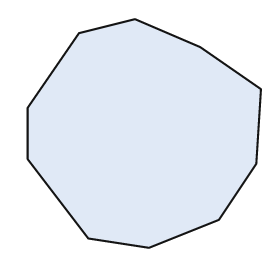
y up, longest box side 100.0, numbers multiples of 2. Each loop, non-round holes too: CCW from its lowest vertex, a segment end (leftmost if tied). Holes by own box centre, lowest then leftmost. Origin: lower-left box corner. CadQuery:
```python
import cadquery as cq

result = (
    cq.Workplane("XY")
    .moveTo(52.0, 0.0)
    .lineTo(82.0, 12.0)
    .lineTo(98.0, 36.0)
    .lineTo(100.0, 68.0)
    .lineTo(74.0, 86.0)
    .lineTo(46.0, 98.0)
    .lineTo(22.0, 92.0)
    .lineTo(0.0, 60.0)
    .lineTo(0.0, 38.0)
    .lineTo(26.0, 4.0)
    .close()
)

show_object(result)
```